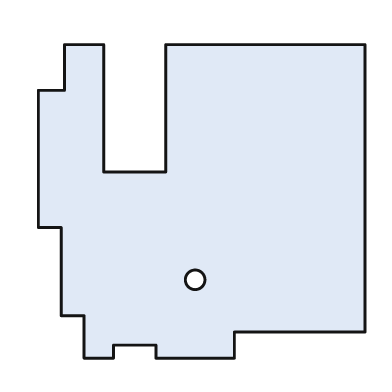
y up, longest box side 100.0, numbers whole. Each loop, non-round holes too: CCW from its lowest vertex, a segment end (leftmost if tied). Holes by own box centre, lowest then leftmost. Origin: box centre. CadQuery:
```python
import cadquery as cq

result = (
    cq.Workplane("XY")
    .moveTo(-36.0, -48.0)
    .lineTo(-27.0, -48.0)
    .lineTo(-27.0, -44.0)
    .lineTo(-14.0, -44.0)
    .lineTo(-14.0, -48.0)
    .lineTo(10.0, -48.0)
    .lineTo(10.0, -40.0)
    .lineTo(50.0, -40.0)
    .lineTo(50.0, 48.0)
    .lineTo(-11.0, 48.0)
    .lineTo(-11.0, 9.0)
    .lineTo(-30.0, 9.0)
    .lineTo(-30.0, 48.0)
    .lineTo(-42.0, 48.0)
    .lineTo(-42.0, 34.0)
    .lineTo(-50.0, 34.0)
    .lineTo(-50.0, -8.0)
    .lineTo(-43.0, -8.0)
    .lineTo(-43.0, -35.0)
    .lineTo(-36.0, -35.0)
    .close()
    .moveTo(-2.0, -24.0)
    .circle(3.0)
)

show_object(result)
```